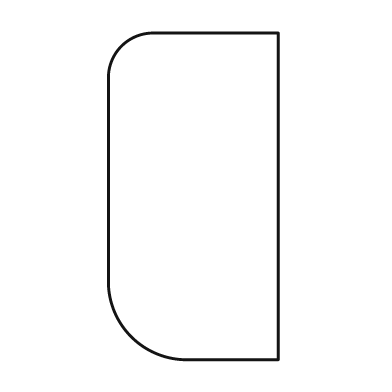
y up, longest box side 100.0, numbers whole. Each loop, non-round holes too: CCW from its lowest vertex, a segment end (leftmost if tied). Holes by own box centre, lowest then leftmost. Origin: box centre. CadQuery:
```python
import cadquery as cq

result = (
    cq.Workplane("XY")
    .moveTo(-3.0, -50.0)
    .lineTo(26.0, -50.0)
    .lineTo(26.0, 50.0)
    .lineTo(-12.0, 50.0)
    .threePointArc((-22.0, 46.0), (-26.0, 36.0))
    .lineTo(-26.0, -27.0)
    .threePointArc((-19.0, -43.0), (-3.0, -50.0))
    .close()
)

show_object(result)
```